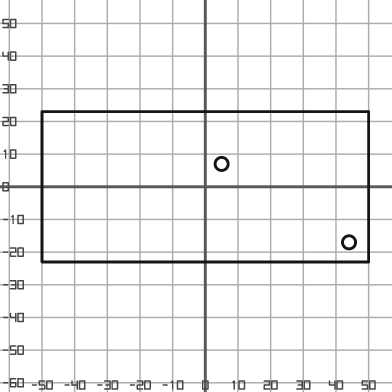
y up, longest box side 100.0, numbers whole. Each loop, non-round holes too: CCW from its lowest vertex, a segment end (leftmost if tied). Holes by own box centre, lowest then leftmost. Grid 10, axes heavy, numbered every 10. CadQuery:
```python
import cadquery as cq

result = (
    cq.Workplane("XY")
    .moveTo(-50.0, -23.0)
    .lineTo(50.0, -23.0)
    .lineTo(50.0, 23.0)
    .lineTo(-50.0, 23.0)
    .close()
    .moveTo(44.0, -17.0)
    .circle(2.0)
    .moveTo(5.0, 7.0)
    .circle(2.0)
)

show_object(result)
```